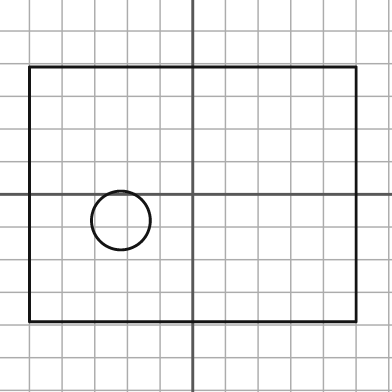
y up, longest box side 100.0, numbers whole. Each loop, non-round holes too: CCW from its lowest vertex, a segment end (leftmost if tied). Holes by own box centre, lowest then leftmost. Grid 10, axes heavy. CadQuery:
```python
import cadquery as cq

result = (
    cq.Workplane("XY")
    .moveTo(-50.0, -39.0)
    .lineTo(50.0, -39.0)
    .lineTo(50.0, 39.0)
    .lineTo(-50.0, 39.0)
    .close()
    .moveTo(-22.0, -8.0)
    .circle(9.0)
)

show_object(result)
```